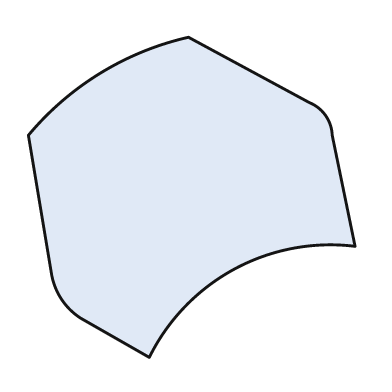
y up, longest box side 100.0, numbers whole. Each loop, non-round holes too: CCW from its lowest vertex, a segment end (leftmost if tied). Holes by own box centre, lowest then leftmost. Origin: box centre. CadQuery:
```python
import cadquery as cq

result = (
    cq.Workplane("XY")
    .moveTo(-13.0, -49.0)
    .threePointArc((13.0, -22.0), (50.0, -15.0))
    .lineTo(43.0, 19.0)
    .threePointArc((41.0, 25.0), (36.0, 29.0))
    .lineTo(-1.0, 49.0)
    .threePointArc((-28.0, 38.0), (-50.0, 19.0))
    .lineTo(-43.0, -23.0)
    .threePointArc((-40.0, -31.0), (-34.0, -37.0))
    .close()
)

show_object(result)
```